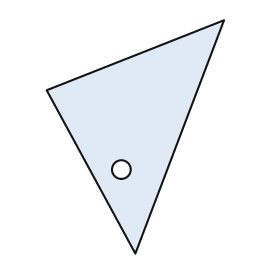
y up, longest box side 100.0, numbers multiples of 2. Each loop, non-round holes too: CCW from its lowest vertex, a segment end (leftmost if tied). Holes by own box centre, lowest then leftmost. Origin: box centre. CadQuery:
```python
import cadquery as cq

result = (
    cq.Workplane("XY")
    .moveTo(0.0, -50.0)
    .lineTo(38.0, 50.0)
    .lineTo(-38.0, 20.0)
    .close()
    .moveTo(-6.0, -14.0)
    .circle(4.0)
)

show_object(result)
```